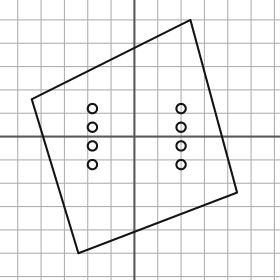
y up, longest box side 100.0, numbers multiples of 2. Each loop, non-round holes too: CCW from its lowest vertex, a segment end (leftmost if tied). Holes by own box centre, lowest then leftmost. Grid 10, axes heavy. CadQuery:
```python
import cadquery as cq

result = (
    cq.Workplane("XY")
    .moveTo(-24.0, -50.0)
    .lineTo(44.0, -24.0)
    .lineTo(24.0, 50.0)
    .lineTo(-44.0, 16.0)
    .close()
    .moveTo(-18.0, -12.0)
    .circle(2.0)
    .moveTo(20.0, -12.0)
    .circle(2.0)
    .moveTo(-18.0, -4.0)
    .circle(2.0)
    .moveTo(20.0, -4.0)
    .circle(2.0)
    .moveTo(-18.0, 4.0)
    .circle(2.0)
    .moveTo(20.0, 4.0)
    .circle(2.0)
    .moveTo(-18.0, 12.0)
    .circle(2.0)
    .moveTo(20.0, 12.0)
    .circle(2.0)
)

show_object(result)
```